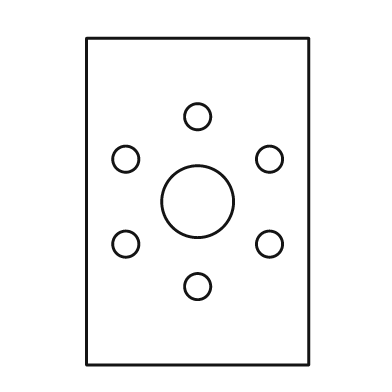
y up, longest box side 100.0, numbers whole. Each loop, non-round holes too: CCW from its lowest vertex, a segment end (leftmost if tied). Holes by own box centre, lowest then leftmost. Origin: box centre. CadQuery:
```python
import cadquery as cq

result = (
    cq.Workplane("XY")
    .moveTo(-34.0, -50.0)
    .lineTo(34.0, -50.0)
    .lineTo(34.0, 50.0)
    .lineTo(-34.0, 50.0)
    .close()
    .moveTo(0.0, -26.0)
    .circle(4.0)
    .moveTo(-22.0, -13.0)
    .circle(4.0)
    .moveTo(22.0, -13.0)
    .circle(4.0)
    .moveTo(0.0, 0.0)
    .circle(11.0)
    .moveTo(-22.0, 13.0)
    .circle(4.0)
    .moveTo(22.0, 13.0)
    .circle(4.0)
    .moveTo(0.0, 26.0)
    .circle(4.0)
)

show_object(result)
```